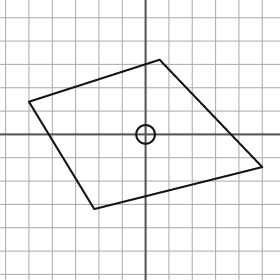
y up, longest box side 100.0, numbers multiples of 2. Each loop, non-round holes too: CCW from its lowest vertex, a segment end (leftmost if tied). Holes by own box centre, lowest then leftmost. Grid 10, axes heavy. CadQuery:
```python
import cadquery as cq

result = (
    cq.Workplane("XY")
    .moveTo(-22.0, -32.0)
    .lineTo(50.0, -14.0)
    .lineTo(6.0, 32.0)
    .lineTo(-50.0, 14.0)
    .close()
    .moveTo(0.0, 0.0)
    .circle(4.0)
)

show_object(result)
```